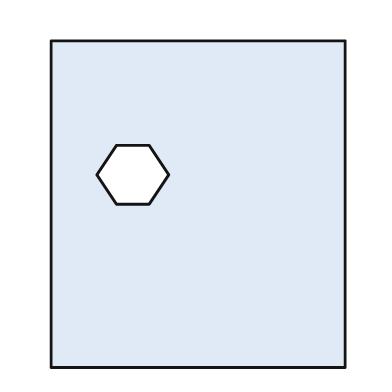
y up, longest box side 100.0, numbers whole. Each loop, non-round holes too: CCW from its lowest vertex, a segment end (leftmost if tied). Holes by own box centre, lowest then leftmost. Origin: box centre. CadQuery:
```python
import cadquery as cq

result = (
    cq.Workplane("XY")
    .moveTo(-45.0, -50.0)
    .lineTo(45.0, -50.0)
    .lineTo(45.0, 50.0)
    .lineTo(-45.0, 50.0)
    .close()
    .moveTo(-25.0, 0.0)
    .lineTo(-15.0, 0.0)
    .lineTo(-9.0, 9.0)
    .lineTo(-15.0, 18.0)
    .lineTo(-25.0, 18.0)
    .lineTo(-31.0, 9.0)
    .close()
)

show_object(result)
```